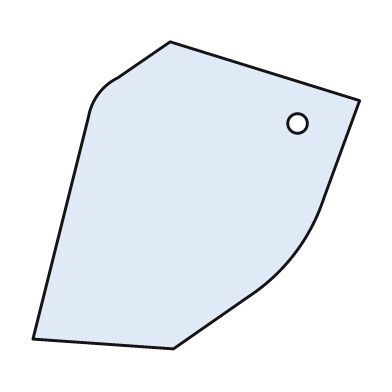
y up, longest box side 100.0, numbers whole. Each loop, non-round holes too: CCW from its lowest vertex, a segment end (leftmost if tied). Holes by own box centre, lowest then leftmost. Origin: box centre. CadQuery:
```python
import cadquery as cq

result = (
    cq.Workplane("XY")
    .moveTo(-7.0, -47.0)
    .lineTo(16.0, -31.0)
    .threePointArc((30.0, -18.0), (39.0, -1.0))
    .lineTo(50.0, 29.0)
    .lineTo(-8.0, 47.0)
    .lineTo(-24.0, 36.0)
    .threePointArc((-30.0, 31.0), (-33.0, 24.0))
    .lineTo(-50.0, -44.0)
    .close()
    .moveTo(31.0, 22.0)
    .circle(3.0)
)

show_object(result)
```